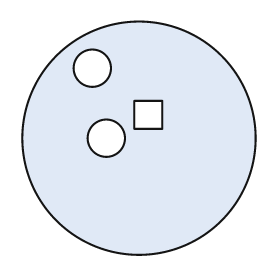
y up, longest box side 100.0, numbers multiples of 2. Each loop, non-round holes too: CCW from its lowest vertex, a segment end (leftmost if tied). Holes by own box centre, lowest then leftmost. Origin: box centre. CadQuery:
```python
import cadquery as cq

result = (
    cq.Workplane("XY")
    .moveTo(0.0, 0.0)
    .circle(50.0)
    .moveTo(-14.0, 0.0)
    .circle(8.0)
    .moveTo(-2.0, 4.0)
    .lineTo(10.0, 4.0)
    .lineTo(10.0, 16.0)
    .lineTo(-2.0, 16.0)
    .close()
    .moveTo(-20.0, 30.0)
    .circle(8.0)
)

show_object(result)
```